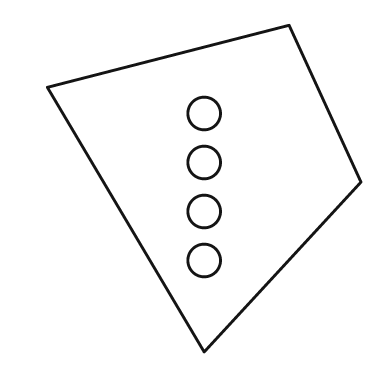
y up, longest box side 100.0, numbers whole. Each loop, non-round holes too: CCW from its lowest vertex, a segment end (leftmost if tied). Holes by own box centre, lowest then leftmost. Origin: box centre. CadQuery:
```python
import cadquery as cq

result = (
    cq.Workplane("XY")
    .moveTo(0.0, -50.0)
    .lineTo(48.0, 2.0)
    .lineTo(26.0, 50.0)
    .lineTo(-48.0, 31.0)
    .close()
    .moveTo(0.0, -22.0)
    .circle(5.0)
    .moveTo(0.0, -7.0)
    .circle(5.0)
    .moveTo(0.0, 8.0)
    .circle(5.0)
    .moveTo(0.0, 23.0)
    .circle(5.0)
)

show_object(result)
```